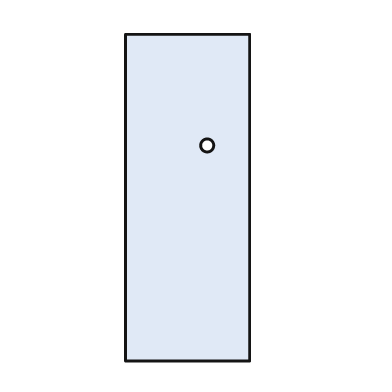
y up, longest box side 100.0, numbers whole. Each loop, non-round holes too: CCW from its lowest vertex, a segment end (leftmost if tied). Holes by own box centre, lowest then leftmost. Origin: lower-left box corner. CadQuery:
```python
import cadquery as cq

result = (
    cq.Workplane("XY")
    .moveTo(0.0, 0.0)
    .lineTo(38.0, 0.0)
    .lineTo(38.0, 100.0)
    .lineTo(0.0, 100.0)
    .close()
    .moveTo(25.0, 66.0)
    .circle(2.0)
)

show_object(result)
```